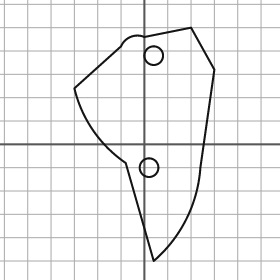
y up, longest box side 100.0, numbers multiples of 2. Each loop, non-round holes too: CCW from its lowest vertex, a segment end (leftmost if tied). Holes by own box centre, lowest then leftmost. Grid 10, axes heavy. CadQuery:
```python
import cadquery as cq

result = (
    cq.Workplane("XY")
    .moveTo(4.0, -50.0)
    .threePointArc((18.0, -32.0), (24.0, -10.0))
    .lineTo(30.0, 32.0)
    .lineTo(20.0, 50.0)
    .lineTo(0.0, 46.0)
    .threePointArc((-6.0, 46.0), (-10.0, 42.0))
    .lineTo(-30.0, 24.0)
    .threePointArc((-22.0, 6.0), (-8.0, -8.0))
    .close()
    .moveTo(2.0, -10.0)
    .circle(4.0)
    .moveTo(4.0, 38.0)
    .circle(4.0)
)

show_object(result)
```